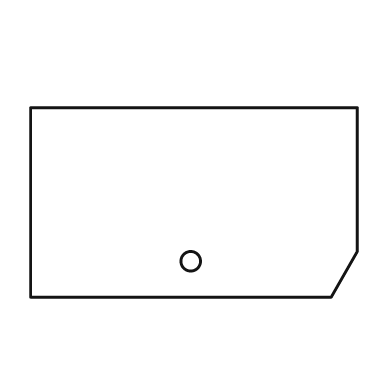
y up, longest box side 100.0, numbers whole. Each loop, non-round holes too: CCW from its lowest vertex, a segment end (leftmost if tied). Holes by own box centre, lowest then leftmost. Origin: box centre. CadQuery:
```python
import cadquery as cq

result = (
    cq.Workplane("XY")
    .moveTo(-50.0, -29.0)
    .lineTo(42.0, -29.0)
    .lineTo(50.0, -15.0)
    .lineTo(50.0, 29.0)
    .lineTo(-50.0, 29.0)
    .close()
    .moveTo(-1.0, -18.0)
    .circle(3.0)
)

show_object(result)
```